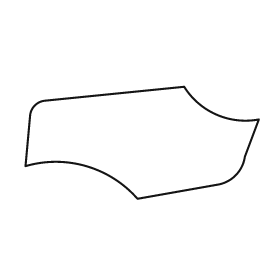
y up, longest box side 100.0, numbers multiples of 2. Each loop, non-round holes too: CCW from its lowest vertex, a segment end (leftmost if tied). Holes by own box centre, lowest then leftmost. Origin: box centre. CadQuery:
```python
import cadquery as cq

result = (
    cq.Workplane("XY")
    .moveTo(-2.0, -24.0)
    .lineTo(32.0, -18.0)
    .threePointArc((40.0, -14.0), (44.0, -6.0))
    .lineTo(50.0, 10.0)
    .threePointArc((32.0, 12.0), (18.0, 24.0))
    .lineTo(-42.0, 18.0)
    .threePointArc((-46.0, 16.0), (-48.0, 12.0))
    .lineTo(-50.0, -10.0)
    .threePointArc((-24.0, -10.0), (-2.0, -24.0))
    .close()
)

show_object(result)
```